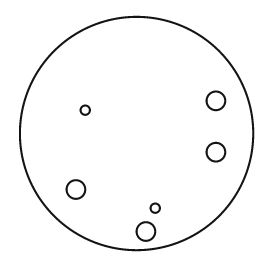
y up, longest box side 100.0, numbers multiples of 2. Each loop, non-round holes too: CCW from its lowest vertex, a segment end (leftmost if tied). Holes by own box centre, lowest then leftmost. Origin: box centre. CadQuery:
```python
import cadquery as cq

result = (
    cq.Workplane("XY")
    .moveTo(0.0, 0.0)
    .circle(50.0)
    .moveTo(4.0, -42.0)
    .circle(4.0)
    .moveTo(8.0, -32.0)
    .circle(2.0)
    .moveTo(-26.0, -24.0)
    .circle(4.0)
    .moveTo(34.0, -8.0)
    .circle(4.0)
    .moveTo(-22.0, 10.0)
    .circle(2.0)
    .moveTo(34.0, 14.0)
    .circle(4.0)
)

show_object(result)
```